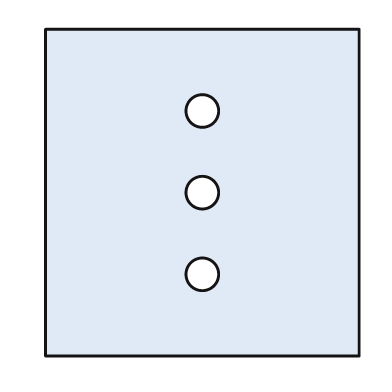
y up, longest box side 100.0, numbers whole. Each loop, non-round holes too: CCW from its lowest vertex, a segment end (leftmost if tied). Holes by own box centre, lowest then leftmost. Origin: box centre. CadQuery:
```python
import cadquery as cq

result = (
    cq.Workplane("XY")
    .moveTo(-48.0, -50.0)
    .lineTo(48.0, -50.0)
    .lineTo(48.0, 50.0)
    .lineTo(-48.0, 50.0)
    .close()
    .moveTo(0.0, -25.0)
    .circle(5.0)
    .moveTo(0.0, 0.0)
    .circle(5.0)
    .moveTo(0.0, 25.0)
    .circle(5.0)
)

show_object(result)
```